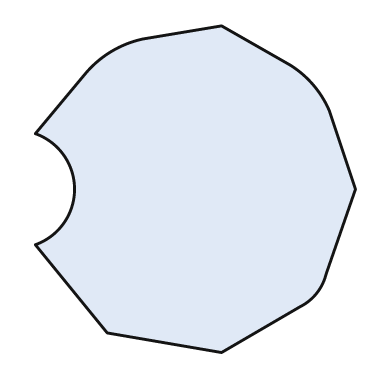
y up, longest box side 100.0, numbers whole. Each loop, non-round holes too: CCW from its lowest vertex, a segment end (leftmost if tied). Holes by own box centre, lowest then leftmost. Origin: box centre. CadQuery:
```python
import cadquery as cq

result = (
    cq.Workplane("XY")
    .moveTo(8.0, -50.0)
    .lineTo(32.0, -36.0)
    .threePointArc((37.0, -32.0), (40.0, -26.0))
    .lineTo(49.0, 0.0)
    .lineTo(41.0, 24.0)
    .threePointArc((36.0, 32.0), (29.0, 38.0))
    .lineTo(8.0, 50.0)
    .lineTo(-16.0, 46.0)
    .threePointArc((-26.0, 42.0), (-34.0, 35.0))
    .lineTo(-49.0, 17.0)
    .threePointArc((-37.0, 0.0), (-49.0, -17.0))
    .lineTo(-27.0, -44.0)
    .close()
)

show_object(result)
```